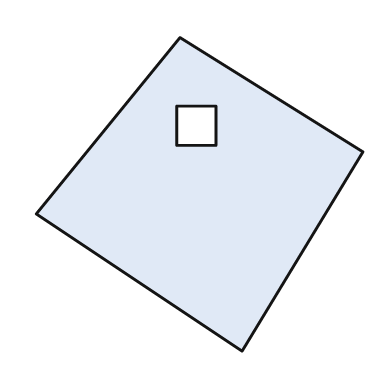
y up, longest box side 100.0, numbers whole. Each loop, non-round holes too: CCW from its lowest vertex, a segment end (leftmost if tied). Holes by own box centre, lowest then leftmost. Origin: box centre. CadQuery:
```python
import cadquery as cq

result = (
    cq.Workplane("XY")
    .moveTo(13.0, -48.0)
    .lineTo(50.0, 13.0)
    .lineTo(-6.0, 48.0)
    .lineTo(-50.0, -6.0)
    .close()
    .moveTo(-7.0, 15.0)
    .lineTo(5.0, 15.0)
    .lineTo(5.0, 27.0)
    .lineTo(-7.0, 27.0)
    .close()
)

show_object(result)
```